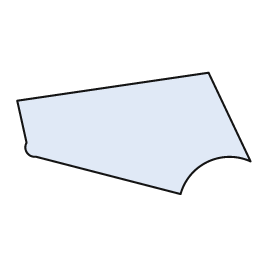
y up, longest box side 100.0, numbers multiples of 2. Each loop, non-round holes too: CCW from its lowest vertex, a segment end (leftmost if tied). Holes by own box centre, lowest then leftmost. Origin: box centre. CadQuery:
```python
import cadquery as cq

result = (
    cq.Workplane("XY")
    .moveTo(20.0, -26.0)
    .threePointArc((32.0, -12.0), (50.0, -12.0))
    .lineTo(32.0, 26.0)
    .lineTo(-50.0, 14.0)
    .lineTo(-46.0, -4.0)
    .threePointArc((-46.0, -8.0), (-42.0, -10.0))
    .close()
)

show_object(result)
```